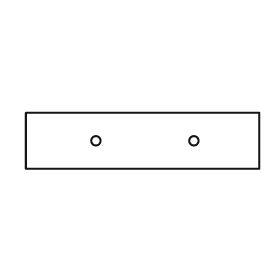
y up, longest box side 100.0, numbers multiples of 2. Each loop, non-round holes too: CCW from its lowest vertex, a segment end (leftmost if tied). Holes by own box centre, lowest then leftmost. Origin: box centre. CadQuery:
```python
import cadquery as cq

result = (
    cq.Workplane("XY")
    .moveTo(-50.0, -12.0)
    .lineTo(50.0, -12.0)
    .lineTo(50.0, 12.0)
    .lineTo(-50.0, 12.0)
    .close()
    .moveTo(-20.0, 0.0)
    .circle(2.0)
    .moveTo(22.0, 0.0)
    .circle(2.0)
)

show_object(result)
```